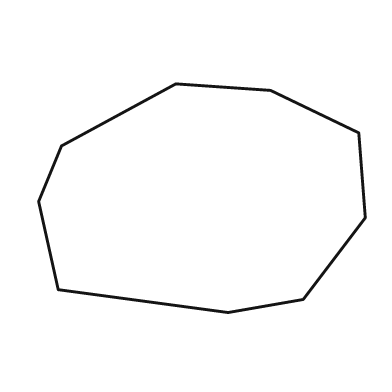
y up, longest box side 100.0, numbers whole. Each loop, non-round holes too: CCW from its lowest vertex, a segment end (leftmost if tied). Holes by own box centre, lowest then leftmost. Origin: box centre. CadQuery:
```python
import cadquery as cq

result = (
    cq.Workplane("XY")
    .moveTo(8.0, -35.0)
    .lineTo(31.0, -31.0)
    .lineTo(50.0, -6.0)
    .lineTo(48.0, 20.0)
    .lineTo(21.0, 33.0)
    .lineTo(-8.0, 35.0)
    .lineTo(-43.0, 16.0)
    .lineTo(-50.0, -1.0)
    .lineTo(-44.0, -28.0)
    .close()
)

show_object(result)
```